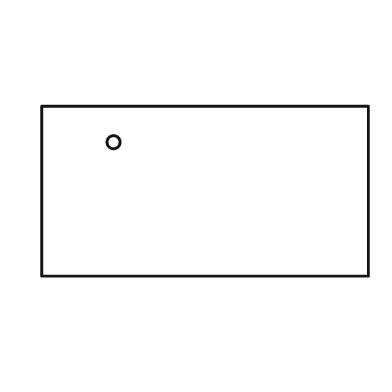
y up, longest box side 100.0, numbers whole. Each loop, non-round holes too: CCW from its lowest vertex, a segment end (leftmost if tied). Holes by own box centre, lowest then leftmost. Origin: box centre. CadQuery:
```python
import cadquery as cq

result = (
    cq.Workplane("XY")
    .moveTo(-50.0, -26.0)
    .lineTo(50.0, -26.0)
    .lineTo(50.0, 26.0)
    .lineTo(-50.0, 26.0)
    .close()
    .moveTo(-28.0, 15.0)
    .circle(2.0)
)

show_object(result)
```